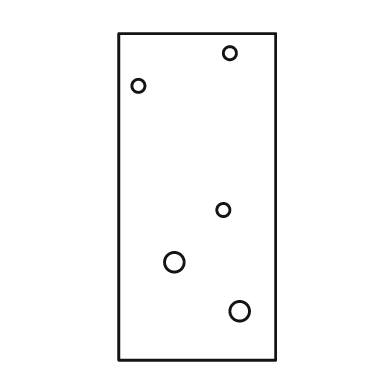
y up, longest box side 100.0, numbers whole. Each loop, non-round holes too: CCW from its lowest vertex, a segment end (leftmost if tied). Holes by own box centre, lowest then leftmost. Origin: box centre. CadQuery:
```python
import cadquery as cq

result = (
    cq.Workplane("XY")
    .moveTo(-24.0, -50.0)
    .lineTo(24.0, -50.0)
    .lineTo(24.0, 50.0)
    .lineTo(-24.0, 50.0)
    .close()
    .moveTo(13.0, -35.0)
    .circle(3.0)
    .moveTo(-7.0, -20.0)
    .circle(3.0)
    .moveTo(8.0, -4.0)
    .circle(2.0)
    .moveTo(-18.0, 34.0)
    .circle(2.0)
    .moveTo(10.0, 44.0)
    .circle(2.0)
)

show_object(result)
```